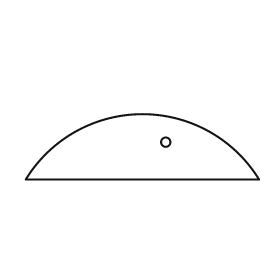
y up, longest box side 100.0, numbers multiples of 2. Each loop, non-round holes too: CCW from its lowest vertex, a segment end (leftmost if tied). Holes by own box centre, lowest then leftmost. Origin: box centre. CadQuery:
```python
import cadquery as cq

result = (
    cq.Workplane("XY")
    .moveTo(-50.0, -14.0)
    .lineTo(50.0, -14.0)
    .threePointArc((0.0, 14.0), (-50.0, -14.0))
    .close()
    .moveTo(10.0, 2.0)
    .circle(2.0)
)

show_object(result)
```